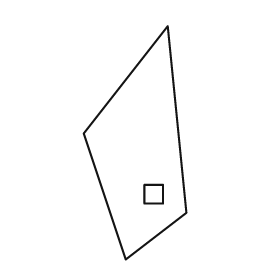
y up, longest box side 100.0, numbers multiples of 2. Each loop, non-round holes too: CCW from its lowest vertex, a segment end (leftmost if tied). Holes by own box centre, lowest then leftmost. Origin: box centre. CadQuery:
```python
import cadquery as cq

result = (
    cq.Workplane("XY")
    .moveTo(-4.0, -50.0)
    .lineTo(22.0, -30.0)
    .lineTo(14.0, 50.0)
    .lineTo(-22.0, 4.0)
    .close()
    .moveTo(4.0, -26.0)
    .lineTo(12.0, -26.0)
    .lineTo(12.0, -18.0)
    .lineTo(4.0, -18.0)
    .close()
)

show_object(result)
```